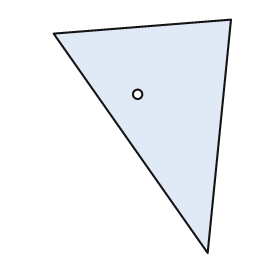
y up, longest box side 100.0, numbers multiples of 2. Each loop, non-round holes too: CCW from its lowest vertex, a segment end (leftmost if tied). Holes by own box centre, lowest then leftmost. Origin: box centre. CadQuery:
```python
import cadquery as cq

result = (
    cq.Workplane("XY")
    .moveTo(28.0, -50.0)
    .lineTo(38.0, 50.0)
    .lineTo(-38.0, 44.0)
    .close()
    .moveTo(-2.0, 18.0)
    .circle(2.0)
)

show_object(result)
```